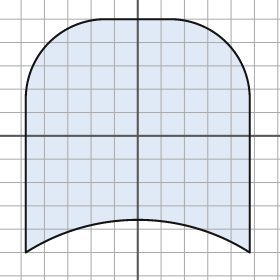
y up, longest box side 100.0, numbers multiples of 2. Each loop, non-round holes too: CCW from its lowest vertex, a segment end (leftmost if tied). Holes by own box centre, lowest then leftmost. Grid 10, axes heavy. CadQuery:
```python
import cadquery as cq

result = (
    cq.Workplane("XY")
    .moveTo(-48.0, -50.0)
    .threePointArc((0.0, -36.0), (48.0, -50.0))
    .lineTo(48.0, 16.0)
    .threePointArc((38.0, 40.0), (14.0, 50.0))
    .lineTo(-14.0, 50.0)
    .threePointArc((-38.0, 40.0), (-48.0, 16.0))
    .close()
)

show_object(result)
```